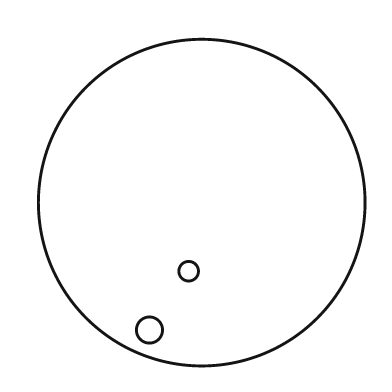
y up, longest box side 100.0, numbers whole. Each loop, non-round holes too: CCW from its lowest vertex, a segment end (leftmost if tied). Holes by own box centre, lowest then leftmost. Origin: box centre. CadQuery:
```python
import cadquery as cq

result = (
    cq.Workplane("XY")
    .moveTo(0.0, 0.0)
    .circle(50.0)
    .moveTo(-16.0, -39.0)
    .circle(4.0)
    .moveTo(-4.0, -21.0)
    .circle(3.0)
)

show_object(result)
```